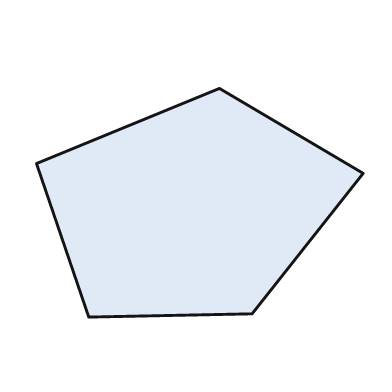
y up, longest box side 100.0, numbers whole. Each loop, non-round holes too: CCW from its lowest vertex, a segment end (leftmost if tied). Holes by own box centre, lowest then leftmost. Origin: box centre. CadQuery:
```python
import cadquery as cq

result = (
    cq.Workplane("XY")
    .moveTo(-34.0, -35.0)
    .lineTo(16.0, -34.0)
    .lineTo(50.0, 9.0)
    .lineTo(6.0, 35.0)
    .lineTo(-50.0, 12.0)
    .close()
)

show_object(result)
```